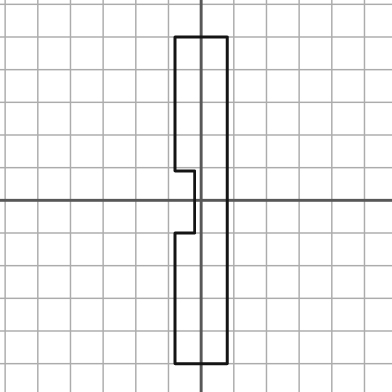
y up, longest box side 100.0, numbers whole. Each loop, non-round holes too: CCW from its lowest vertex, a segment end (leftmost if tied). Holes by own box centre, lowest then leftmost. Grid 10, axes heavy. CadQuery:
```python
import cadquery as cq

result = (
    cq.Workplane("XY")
    .moveTo(-8.0, -50.0)
    .lineTo(8.0, -50.0)
    .lineTo(8.0, 50.0)
    .lineTo(-8.0, 50.0)
    .lineTo(-8.0, 9.0)
    .lineTo(-2.0, 9.0)
    .lineTo(-2.0, -10.0)
    .lineTo(-8.0, -10.0)
    .close()
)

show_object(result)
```